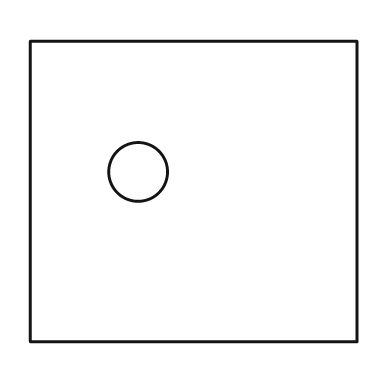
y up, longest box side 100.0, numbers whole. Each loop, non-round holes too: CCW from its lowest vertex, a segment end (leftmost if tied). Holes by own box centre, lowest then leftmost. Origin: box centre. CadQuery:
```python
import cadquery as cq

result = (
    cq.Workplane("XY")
    .moveTo(-50.0, -46.0)
    .lineTo(50.0, -46.0)
    .lineTo(50.0, 46.0)
    .lineTo(-50.0, 46.0)
    .close()
    .moveTo(-17.0, 6.0)
    .circle(9.0)
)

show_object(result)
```